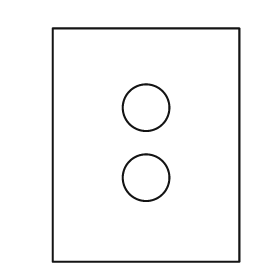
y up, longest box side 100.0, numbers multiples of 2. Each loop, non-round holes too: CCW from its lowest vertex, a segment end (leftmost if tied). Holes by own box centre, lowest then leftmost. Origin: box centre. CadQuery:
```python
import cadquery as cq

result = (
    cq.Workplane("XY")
    .moveTo(-40.0, -50.0)
    .lineTo(40.0, -50.0)
    .lineTo(40.0, 50.0)
    .lineTo(-40.0, 50.0)
    .close()
    .moveTo(0.0, -14.0)
    .circle(10.0)
    .moveTo(0.0, 16.0)
    .circle(10.0)
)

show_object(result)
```